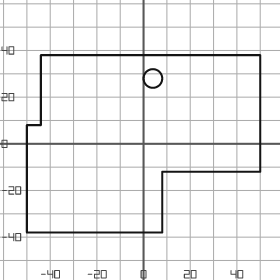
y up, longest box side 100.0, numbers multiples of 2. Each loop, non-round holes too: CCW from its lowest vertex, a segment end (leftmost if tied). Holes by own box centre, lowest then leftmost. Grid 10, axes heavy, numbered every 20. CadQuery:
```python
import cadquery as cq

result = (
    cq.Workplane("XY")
    .moveTo(-50.0, -38.0)
    .lineTo(8.0, -38.0)
    .lineTo(8.0, -12.0)
    .lineTo(50.0, -12.0)
    .lineTo(50.0, 38.0)
    .lineTo(-44.0, 38.0)
    .lineTo(-44.0, 8.0)
    .lineTo(-50.0, 8.0)
    .close()
    .moveTo(4.0, 28.0)
    .circle(4.0)
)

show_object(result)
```